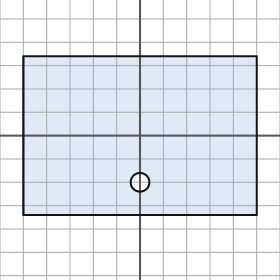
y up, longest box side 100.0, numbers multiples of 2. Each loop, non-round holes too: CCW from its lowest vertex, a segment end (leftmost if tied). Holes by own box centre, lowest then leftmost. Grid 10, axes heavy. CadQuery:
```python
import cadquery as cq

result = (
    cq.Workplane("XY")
    .moveTo(-50.0, -34.0)
    .lineTo(50.0, -34.0)
    .lineTo(50.0, 34.0)
    .lineTo(-50.0, 34.0)
    .close()
    .moveTo(0.0, -20.0)
    .circle(4.0)
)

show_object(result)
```